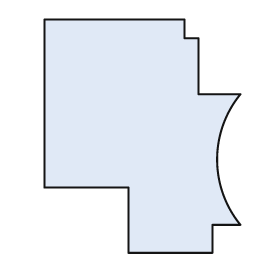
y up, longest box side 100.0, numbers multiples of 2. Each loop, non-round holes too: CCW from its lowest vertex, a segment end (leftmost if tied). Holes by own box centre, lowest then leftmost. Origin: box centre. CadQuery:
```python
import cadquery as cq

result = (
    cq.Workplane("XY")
    .moveTo(-6.0, -50.0)
    .lineTo(30.0, -50.0)
    .lineTo(30.0, -38.0)
    .lineTo(42.0, -38.0)
    .threePointArc((32.0, -10.0), (42.0, 18.0))
    .lineTo(24.0, 18.0)
    .lineTo(24.0, 42.0)
    .lineTo(18.0, 42.0)
    .lineTo(18.0, 50.0)
    .lineTo(-42.0, 50.0)
    .lineTo(-42.0, -22.0)
    .lineTo(-6.0, -22.0)
    .close()
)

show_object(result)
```